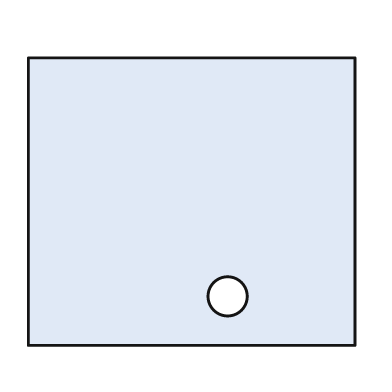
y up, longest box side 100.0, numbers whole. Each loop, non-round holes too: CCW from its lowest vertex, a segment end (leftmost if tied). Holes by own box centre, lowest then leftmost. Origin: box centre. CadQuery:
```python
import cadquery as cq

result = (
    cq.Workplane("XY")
    .moveTo(-50.0, -44.0)
    .lineTo(50.0, -44.0)
    .lineTo(50.0, 44.0)
    .lineTo(-50.0, 44.0)
    .close()
    .moveTo(11.0, -29.0)
    .circle(6.0)
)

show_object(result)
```